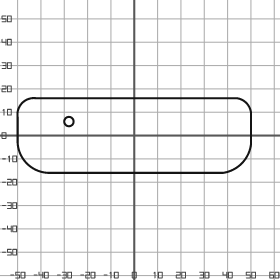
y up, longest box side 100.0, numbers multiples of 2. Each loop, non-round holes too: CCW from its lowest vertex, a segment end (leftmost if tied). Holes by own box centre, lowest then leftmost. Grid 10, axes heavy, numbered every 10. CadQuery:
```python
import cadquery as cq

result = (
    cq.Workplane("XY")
    .moveTo(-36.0, -16.0)
    .lineTo(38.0, -16.0)
    .threePointArc((46.0, -12.0), (50.0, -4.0))
    .lineTo(50.0, 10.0)
    .threePointArc((48.0, 14.0), (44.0, 16.0))
    .lineTo(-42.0, 16.0)
    .threePointArc((-48.0, 14.0), (-50.0, 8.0))
    .lineTo(-50.0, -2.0)
    .threePointArc((-46.0, -12.0), (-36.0, -16.0))
    .close()
    .moveTo(-28.0, 6.0)
    .circle(2.0)
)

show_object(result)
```